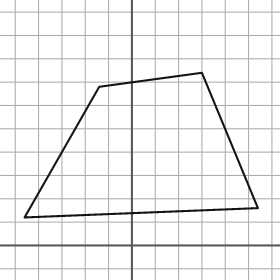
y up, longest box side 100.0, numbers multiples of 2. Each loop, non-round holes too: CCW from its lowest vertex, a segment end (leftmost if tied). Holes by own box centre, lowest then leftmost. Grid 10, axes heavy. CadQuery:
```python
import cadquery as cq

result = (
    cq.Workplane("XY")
    .moveTo(-46.0, 12.0)
    .lineTo(54.0, 16.0)
    .lineTo(30.0, 74.0)
    .lineTo(-14.0, 68.0)
    .close()
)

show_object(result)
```